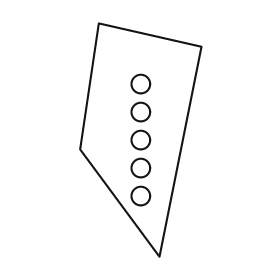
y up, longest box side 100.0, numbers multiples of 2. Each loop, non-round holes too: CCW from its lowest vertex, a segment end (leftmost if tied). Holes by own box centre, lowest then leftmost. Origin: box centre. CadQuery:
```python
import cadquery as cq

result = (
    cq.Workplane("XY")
    .moveTo(8.0, -50.0)
    .lineTo(26.0, 40.0)
    .lineTo(-18.0, 50.0)
    .lineTo(-26.0, -4.0)
    .close()
    .moveTo(0.0, -24.0)
    .circle(4.0)
    .moveTo(0.0, -12.0)
    .circle(4.0)
    .moveTo(0.0, 0.0)
    .circle(4.0)
    .moveTo(0.0, 12.0)
    .circle(4.0)
    .moveTo(0.0, 24.0)
    .circle(4.0)
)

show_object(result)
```